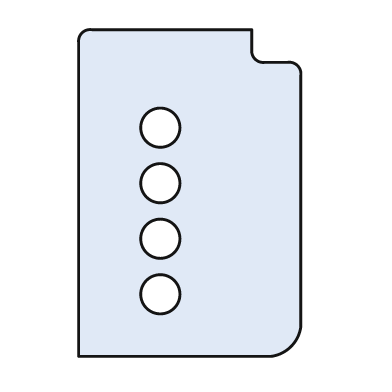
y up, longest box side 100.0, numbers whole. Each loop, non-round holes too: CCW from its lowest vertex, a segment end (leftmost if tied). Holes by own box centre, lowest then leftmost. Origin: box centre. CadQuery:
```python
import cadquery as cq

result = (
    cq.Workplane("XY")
    .moveTo(-34.0, -50.0)
    .lineTo(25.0, -50.0)
    .threePointArc((31.0, -47.0), (34.0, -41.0))
    .lineTo(34.0, 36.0)
    .threePointArc((33.0, 39.0), (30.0, 40.0))
    .lineTo(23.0, 40.0)
    .threePointArc((20.0, 41.0), (19.0, 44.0))
    .lineTo(19.0, 50.0)
    .lineTo(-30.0, 50.0)
    .threePointArc((-33.0, 49.0), (-34.0, 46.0))
    .close()
    .moveTo(-9.0, -31.0)
    .circle(6.0)
    .moveTo(-9.0, -14.0)
    .circle(6.0)
    .moveTo(-9.0, 3.0)
    .circle(6.0)
    .moveTo(-9.0, 20.0)
    .circle(6.0)
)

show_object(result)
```